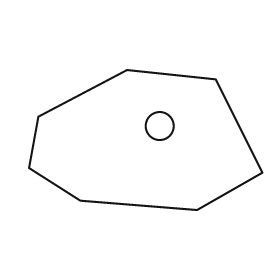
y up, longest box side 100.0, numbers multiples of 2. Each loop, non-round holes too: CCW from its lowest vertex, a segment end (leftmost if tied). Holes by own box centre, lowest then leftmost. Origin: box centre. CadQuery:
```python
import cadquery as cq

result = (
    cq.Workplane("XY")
    .moveTo(22.0, -30.0)
    .lineTo(50.0, -14.0)
    .lineTo(30.0, 26.0)
    .lineTo(-8.0, 30.0)
    .lineTo(-46.0, 10.0)
    .lineTo(-50.0, -12.0)
    .lineTo(-28.0, -26.0)
    .close()
    .moveTo(6.0, 6.0)
    .circle(6.0)
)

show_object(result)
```